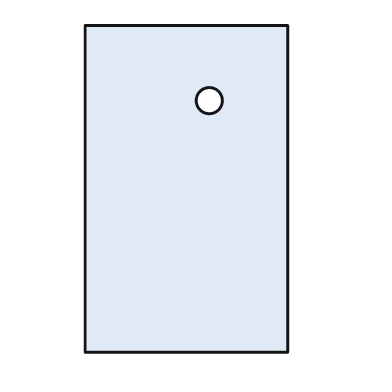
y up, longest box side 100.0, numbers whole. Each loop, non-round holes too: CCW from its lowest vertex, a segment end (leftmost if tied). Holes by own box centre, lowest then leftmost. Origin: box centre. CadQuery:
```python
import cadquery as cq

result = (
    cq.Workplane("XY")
    .moveTo(-31.0, -50.0)
    .lineTo(31.0, -50.0)
    .lineTo(31.0, 50.0)
    .lineTo(-31.0, 50.0)
    .close()
    .moveTo(7.0, 27.0)
    .circle(4.0)
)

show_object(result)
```